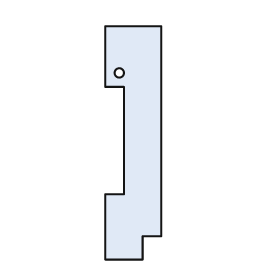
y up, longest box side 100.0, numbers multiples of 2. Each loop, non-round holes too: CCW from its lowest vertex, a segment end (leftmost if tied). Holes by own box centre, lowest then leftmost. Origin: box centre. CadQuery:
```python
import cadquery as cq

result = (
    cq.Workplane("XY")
    .moveTo(-12.0, -50.0)
    .lineTo(4.0, -50.0)
    .lineTo(4.0, -40.0)
    .lineTo(12.0, -40.0)
    .lineTo(12.0, 50.0)
    .lineTo(-12.0, 50.0)
    .lineTo(-12.0, 24.0)
    .lineTo(-4.0, 24.0)
    .lineTo(-4.0, -22.0)
    .lineTo(-12.0, -22.0)
    .close()
    .moveTo(-6.0, 30.0)
    .circle(2.0)
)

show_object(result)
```